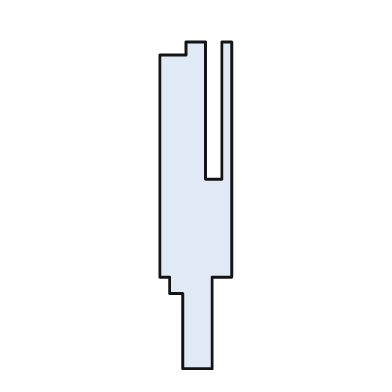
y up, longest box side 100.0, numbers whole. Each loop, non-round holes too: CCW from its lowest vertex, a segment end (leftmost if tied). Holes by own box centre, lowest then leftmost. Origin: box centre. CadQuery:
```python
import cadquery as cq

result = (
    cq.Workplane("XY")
    .moveTo(-4.0, -50.0)
    .lineTo(5.0, -50.0)
    .lineTo(5.0, -22.0)
    .lineTo(11.0, -22.0)
    .lineTo(11.0, 50.0)
    .lineTo(8.0, 50.0)
    .lineTo(8.0, 8.0)
    .lineTo(3.0, 8.0)
    .lineTo(3.0, 50.0)
    .lineTo(-3.0, 50.0)
    .lineTo(-3.0, 46.0)
    .lineTo(-11.0, 46.0)
    .lineTo(-11.0, -22.0)
    .lineTo(-8.0, -22.0)
    .lineTo(-8.0, -27.0)
    .lineTo(-4.0, -27.0)
    .close()
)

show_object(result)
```